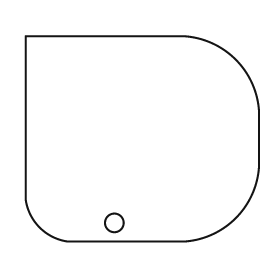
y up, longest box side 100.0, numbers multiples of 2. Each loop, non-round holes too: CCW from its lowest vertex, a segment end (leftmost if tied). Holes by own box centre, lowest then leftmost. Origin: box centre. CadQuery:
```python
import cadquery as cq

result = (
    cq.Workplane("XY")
    .moveTo(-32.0, -44.0)
    .lineTo(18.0, -44.0)
    .threePointArc((40.0, -34.0), (50.0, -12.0))
    .lineTo(50.0, 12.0)
    .threePointArc((40.0, 34.0), (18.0, 44.0))
    .lineTo(-50.0, 44.0)
    .lineTo(-50.0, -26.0)
    .threePointArc((-44.0, -38.0), (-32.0, -44.0))
    .close()
    .moveTo(-12.0, -36.0)
    .circle(4.0)
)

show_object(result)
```